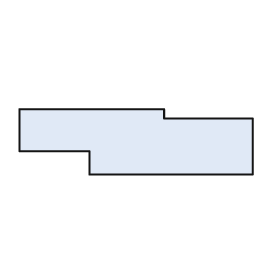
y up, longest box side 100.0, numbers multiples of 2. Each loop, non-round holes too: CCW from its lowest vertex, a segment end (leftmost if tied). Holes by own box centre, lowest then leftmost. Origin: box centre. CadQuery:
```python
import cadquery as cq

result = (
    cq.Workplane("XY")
    .moveTo(-20.0, -14.0)
    .lineTo(50.0, -14.0)
    .lineTo(50.0, 10.0)
    .lineTo(12.0, 10.0)
    .lineTo(12.0, 14.0)
    .lineTo(-50.0, 14.0)
    .lineTo(-50.0, -4.0)
    .lineTo(-20.0, -4.0)
    .close()
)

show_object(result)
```